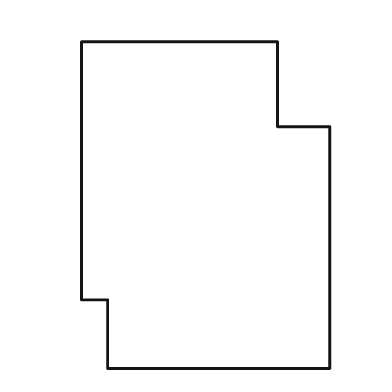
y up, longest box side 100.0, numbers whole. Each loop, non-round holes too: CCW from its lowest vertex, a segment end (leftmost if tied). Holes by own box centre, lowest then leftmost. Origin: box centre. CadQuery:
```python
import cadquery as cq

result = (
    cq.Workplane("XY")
    .moveTo(-30.0, -50.0)
    .lineTo(38.0, -50.0)
    .lineTo(38.0, 24.0)
    .lineTo(22.0, 24.0)
    .lineTo(22.0, 50.0)
    .lineTo(-38.0, 50.0)
    .lineTo(-38.0, -29.0)
    .lineTo(-30.0, -29.0)
    .close()
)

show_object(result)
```